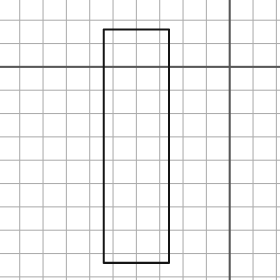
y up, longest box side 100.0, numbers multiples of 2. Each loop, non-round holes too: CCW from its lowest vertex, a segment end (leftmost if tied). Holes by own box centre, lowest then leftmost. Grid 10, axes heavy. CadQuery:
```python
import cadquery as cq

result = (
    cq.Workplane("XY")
    .moveTo(-54.0, -84.0)
    .lineTo(-26.0, -84.0)
    .lineTo(-26.0, 16.0)
    .lineTo(-54.0, 16.0)
    .close()
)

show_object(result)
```